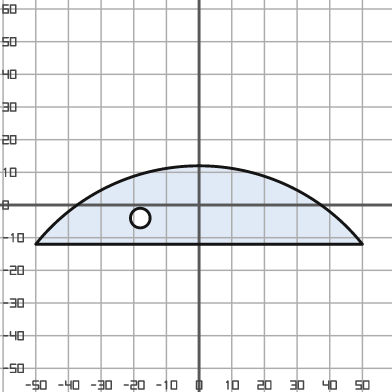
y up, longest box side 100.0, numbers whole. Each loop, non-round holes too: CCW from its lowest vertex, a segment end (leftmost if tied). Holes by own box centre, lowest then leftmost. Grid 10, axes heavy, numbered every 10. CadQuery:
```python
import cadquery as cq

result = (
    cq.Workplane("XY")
    .moveTo(-50.0, -12.0)
    .lineTo(50.0, -12.0)
    .threePointArc((0.0, 12.0), (-50.0, -12.0))
    .close()
    .moveTo(-18.0, -4.0)
    .circle(3.0)
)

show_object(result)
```